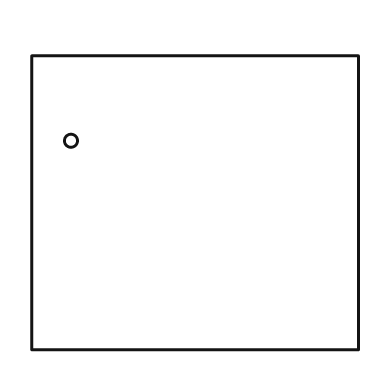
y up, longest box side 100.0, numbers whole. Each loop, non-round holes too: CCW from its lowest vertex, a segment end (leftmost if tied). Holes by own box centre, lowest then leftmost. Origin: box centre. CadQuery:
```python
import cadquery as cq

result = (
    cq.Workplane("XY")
    .moveTo(-50.0, -45.0)
    .lineTo(50.0, -45.0)
    .lineTo(50.0, 45.0)
    .lineTo(-50.0, 45.0)
    .close()
    .moveTo(-38.0, 19.0)
    .circle(2.0)
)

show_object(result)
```